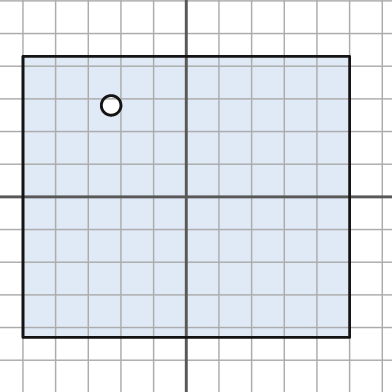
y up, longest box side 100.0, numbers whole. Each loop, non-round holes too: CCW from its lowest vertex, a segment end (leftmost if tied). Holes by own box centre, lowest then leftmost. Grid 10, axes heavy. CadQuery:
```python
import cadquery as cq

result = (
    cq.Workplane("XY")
    .moveTo(-50.0, -43.0)
    .lineTo(50.0, -43.0)
    .lineTo(50.0, 43.0)
    .lineTo(-50.0, 43.0)
    .close()
    .moveTo(-23.0, 28.0)
    .circle(3.0)
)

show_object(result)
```